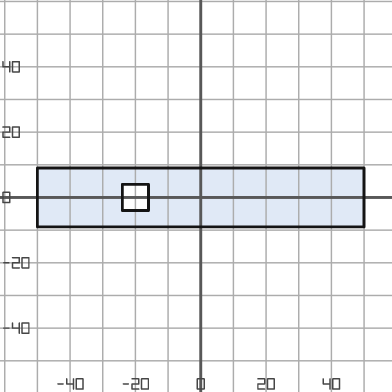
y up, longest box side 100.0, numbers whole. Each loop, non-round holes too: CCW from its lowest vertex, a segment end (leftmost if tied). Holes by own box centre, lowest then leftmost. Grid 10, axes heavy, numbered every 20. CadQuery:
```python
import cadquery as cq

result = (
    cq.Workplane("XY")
    .moveTo(-50.0, -9.0)
    .lineTo(50.0, -9.0)
    .lineTo(50.0, 9.0)
    .lineTo(-50.0, 9.0)
    .close()
    .moveTo(-24.0, -4.0)
    .lineTo(-16.0, -4.0)
    .lineTo(-16.0, 4.0)
    .lineTo(-24.0, 4.0)
    .close()
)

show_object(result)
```